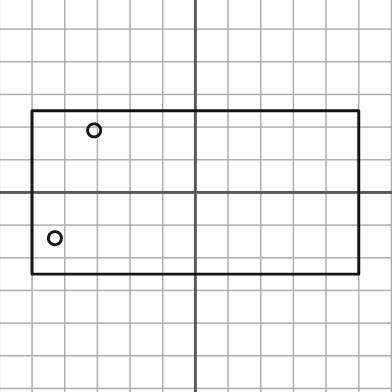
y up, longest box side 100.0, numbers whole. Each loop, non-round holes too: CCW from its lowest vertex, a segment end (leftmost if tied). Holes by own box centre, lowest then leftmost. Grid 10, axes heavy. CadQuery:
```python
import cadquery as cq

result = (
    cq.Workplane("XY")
    .moveTo(-50.0, -25.0)
    .lineTo(50.0, -25.0)
    .lineTo(50.0, 25.0)
    .lineTo(-50.0, 25.0)
    .close()
    .moveTo(-43.0, -14.0)
    .circle(2.0)
    .moveTo(-31.0, 19.0)
    .circle(2.0)
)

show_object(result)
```